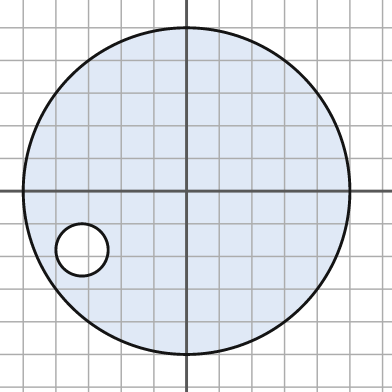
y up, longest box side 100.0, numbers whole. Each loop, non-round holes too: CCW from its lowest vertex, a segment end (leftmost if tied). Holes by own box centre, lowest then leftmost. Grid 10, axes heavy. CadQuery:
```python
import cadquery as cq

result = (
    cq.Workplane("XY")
    .moveTo(0.0, 0.0)
    .circle(50.0)
    .moveTo(-32.0, -18.0)
    .circle(8.0)
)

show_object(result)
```